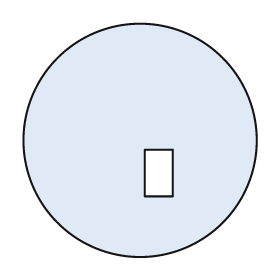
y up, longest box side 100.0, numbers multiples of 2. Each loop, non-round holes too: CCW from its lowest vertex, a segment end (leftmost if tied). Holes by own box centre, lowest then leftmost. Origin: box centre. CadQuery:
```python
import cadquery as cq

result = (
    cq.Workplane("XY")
    .moveTo(0.0, 0.0)
    .circle(50.0)
    .moveTo(2.0, -24.0)
    .lineTo(14.0, -24.0)
    .lineTo(14.0, -4.0)
    .lineTo(2.0, -4.0)
    .close()
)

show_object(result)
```